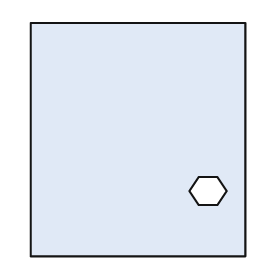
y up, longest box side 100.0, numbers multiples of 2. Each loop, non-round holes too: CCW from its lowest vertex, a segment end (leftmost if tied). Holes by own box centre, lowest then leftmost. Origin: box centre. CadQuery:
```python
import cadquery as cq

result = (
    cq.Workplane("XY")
    .moveTo(-46.0, -50.0)
    .lineTo(46.0, -50.0)
    .lineTo(46.0, 50.0)
    .lineTo(-46.0, 50.0)
    .close()
    .moveTo(26.0, -28.0)
    .lineTo(34.0, -28.0)
    .lineTo(38.0, -22.0)
    .lineTo(34.0, -16.0)
    .lineTo(26.0, -16.0)
    .lineTo(22.0, -22.0)
    .close()
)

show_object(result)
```